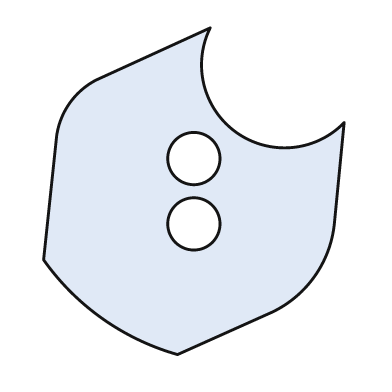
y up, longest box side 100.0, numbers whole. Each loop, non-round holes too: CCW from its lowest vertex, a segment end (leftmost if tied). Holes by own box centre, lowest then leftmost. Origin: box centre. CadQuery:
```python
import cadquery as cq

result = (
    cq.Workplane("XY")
    .moveTo(-5.0, -50.0)
    .lineTo(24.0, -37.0)
    .threePointArc((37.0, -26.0), (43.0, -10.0))
    .lineTo(46.0, 21.0)
    .threePointArc((13.0, 18.0), (5.0, 50.0))
    .lineTo(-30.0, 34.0)
    .threePointArc((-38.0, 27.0), (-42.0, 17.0))
    .lineTo(-46.0, -21.0)
    .threePointArc((-28.0, -39.0), (-5.0, -50.0))
    .close()
    .moveTo(0.0, -10.0)
    .circle(8.0)
    .moveTo(0.0, 10.0)
    .circle(8.0)
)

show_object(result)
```